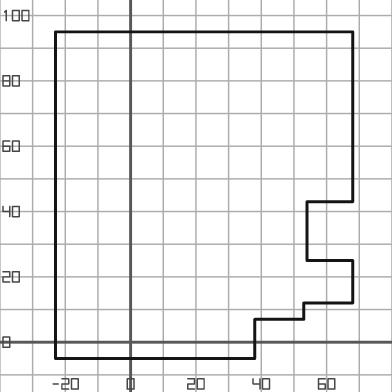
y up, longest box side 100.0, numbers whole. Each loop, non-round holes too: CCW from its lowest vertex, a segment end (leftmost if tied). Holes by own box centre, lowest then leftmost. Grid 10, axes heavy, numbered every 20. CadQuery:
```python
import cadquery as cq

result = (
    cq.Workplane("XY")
    .moveTo(-23.0, -5.0)
    .lineTo(38.0, -5.0)
    .lineTo(38.0, 7.0)
    .lineTo(53.0, 7.0)
    .lineTo(53.0, 12.0)
    .lineTo(68.0, 12.0)
    .lineTo(68.0, 25.0)
    .lineTo(54.0, 25.0)
    .lineTo(54.0, 43.0)
    .lineTo(68.0, 43.0)
    .lineTo(68.0, 95.0)
    .lineTo(-23.0, 95.0)
    .close()
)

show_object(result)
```